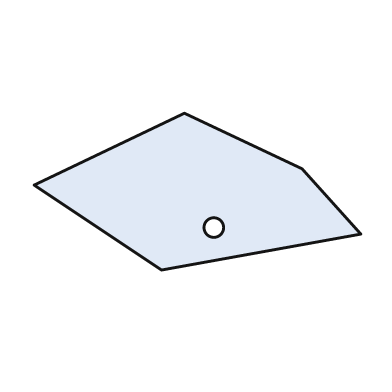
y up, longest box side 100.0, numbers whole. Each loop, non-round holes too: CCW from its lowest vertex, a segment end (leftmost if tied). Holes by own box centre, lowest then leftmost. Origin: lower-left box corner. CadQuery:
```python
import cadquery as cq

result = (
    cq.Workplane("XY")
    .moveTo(39.0, 0.0)
    .lineTo(100.0, 11.0)
    .lineTo(82.0, 31.0)
    .lineTo(46.0, 48.0)
    .lineTo(0.0, 26.0)
    .close()
    .moveTo(55.0, 13.0)
    .circle(3.0)
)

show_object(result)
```